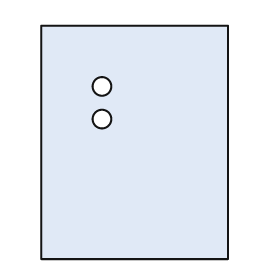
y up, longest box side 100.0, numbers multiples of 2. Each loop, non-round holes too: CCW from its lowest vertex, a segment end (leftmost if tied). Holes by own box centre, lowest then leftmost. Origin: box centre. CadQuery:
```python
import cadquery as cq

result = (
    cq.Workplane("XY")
    .moveTo(-40.0, -50.0)
    .lineTo(40.0, -50.0)
    .lineTo(40.0, 50.0)
    .lineTo(-40.0, 50.0)
    .close()
    .moveTo(-14.0, 10.0)
    .circle(4.0)
    .moveTo(-14.0, 24.0)
    .circle(4.0)
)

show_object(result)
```